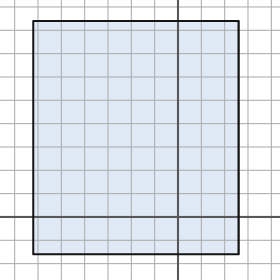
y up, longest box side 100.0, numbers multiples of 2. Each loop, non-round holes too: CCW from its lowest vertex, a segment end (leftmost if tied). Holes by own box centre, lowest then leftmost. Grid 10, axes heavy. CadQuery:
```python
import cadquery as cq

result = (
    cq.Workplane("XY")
    .moveTo(-62.0, -16.0)
    .lineTo(26.0, -16.0)
    .lineTo(26.0, 84.0)
    .lineTo(-62.0, 84.0)
    .close()
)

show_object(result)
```